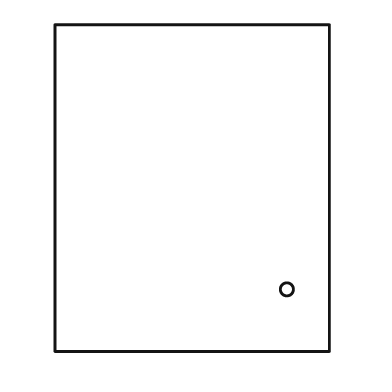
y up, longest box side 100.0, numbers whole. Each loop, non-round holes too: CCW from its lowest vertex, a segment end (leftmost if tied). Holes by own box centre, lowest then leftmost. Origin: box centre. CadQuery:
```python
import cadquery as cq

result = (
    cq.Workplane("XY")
    .moveTo(-42.0, -50.0)
    .lineTo(42.0, -50.0)
    .lineTo(42.0, 50.0)
    .lineTo(-42.0, 50.0)
    .close()
    .moveTo(29.0, -31.0)
    .circle(2.0)
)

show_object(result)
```